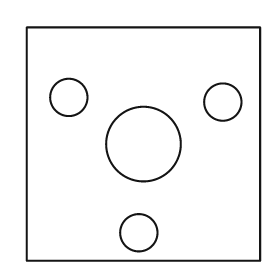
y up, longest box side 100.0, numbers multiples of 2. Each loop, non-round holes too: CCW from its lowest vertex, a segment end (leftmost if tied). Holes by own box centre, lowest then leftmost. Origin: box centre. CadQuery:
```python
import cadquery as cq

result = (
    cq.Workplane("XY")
    .moveTo(-50.0, -50.0)
    .lineTo(50.0, -50.0)
    .lineTo(50.0, 50.0)
    .lineTo(-50.0, 50.0)
    .close()
    .moveTo(-2.0, -38.0)
    .circle(8.0)
    .moveTo(0.0, 0.0)
    .circle(16.0)
    .moveTo(34.0, 18.0)
    .circle(8.0)
    .moveTo(-32.0, 20.0)
    .circle(8.0)
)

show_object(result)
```